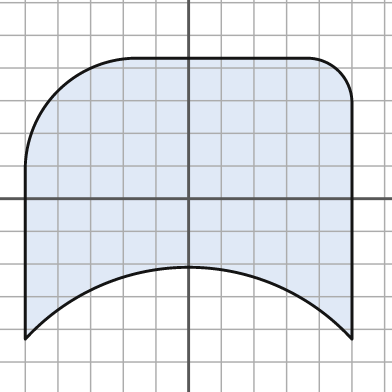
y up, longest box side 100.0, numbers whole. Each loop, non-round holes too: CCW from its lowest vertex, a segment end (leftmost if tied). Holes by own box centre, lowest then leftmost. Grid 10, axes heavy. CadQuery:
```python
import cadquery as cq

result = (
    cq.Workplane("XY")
    .moveTo(-50.0, -43.0)
    .threePointArc((0.0, -21.0), (50.0, -43.0))
    .lineTo(50.0, 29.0)
    .threePointArc((46.0, 39.0), (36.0, 43.0))
    .lineTo(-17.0, 43.0)
    .threePointArc((-40.0, 33.0), (-50.0, 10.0))
    .close()
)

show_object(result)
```